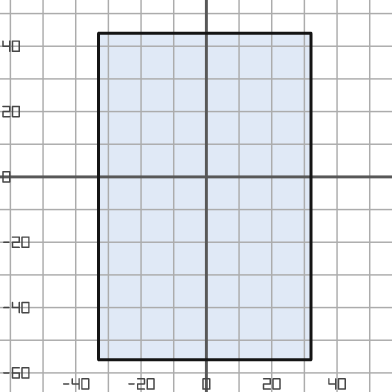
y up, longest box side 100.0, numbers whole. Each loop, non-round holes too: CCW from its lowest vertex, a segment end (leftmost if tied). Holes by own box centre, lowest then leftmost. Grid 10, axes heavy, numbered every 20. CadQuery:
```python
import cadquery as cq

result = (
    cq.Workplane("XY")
    .moveTo(-33.0, -56.0)
    .lineTo(32.0, -56.0)
    .lineTo(32.0, 44.0)
    .lineTo(-33.0, 44.0)
    .close()
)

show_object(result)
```